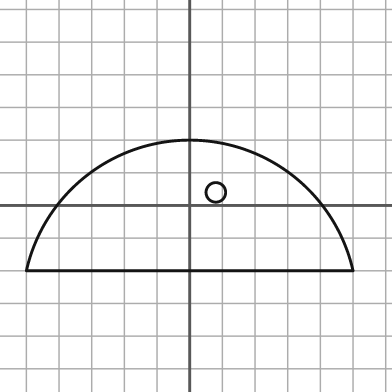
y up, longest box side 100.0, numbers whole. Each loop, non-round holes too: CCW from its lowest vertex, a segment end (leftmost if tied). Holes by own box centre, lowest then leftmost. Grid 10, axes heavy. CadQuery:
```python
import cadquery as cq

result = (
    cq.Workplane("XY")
    .moveTo(-50.0, -20.0)
    .lineTo(50.0, -20.0)
    .threePointArc((0.0, 20.0), (-50.0, -20.0))
    .close()
    .moveTo(8.0, 4.0)
    .circle(3.0)
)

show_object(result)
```